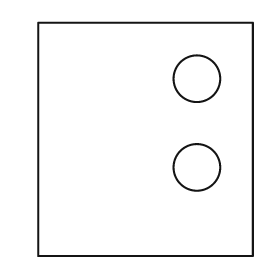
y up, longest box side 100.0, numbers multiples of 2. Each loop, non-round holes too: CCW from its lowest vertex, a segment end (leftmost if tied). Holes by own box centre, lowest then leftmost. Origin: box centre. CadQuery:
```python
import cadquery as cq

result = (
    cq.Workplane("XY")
    .moveTo(-46.0, -50.0)
    .lineTo(46.0, -50.0)
    .lineTo(46.0, 50.0)
    .lineTo(-46.0, 50.0)
    .close()
    .moveTo(22.0, -12.0)
    .circle(10.0)
    .moveTo(22.0, 26.0)
    .circle(10.0)
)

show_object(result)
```